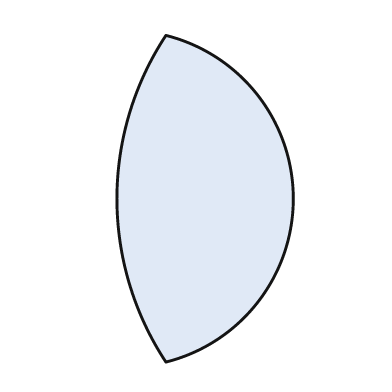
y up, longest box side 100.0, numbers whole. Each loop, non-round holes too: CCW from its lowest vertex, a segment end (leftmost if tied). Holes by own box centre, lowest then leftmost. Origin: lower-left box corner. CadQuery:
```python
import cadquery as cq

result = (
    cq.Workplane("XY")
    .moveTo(15.0, 0.0)
    .threePointArc((54.0, 50.0), (15.0, 100.0))
    .threePointArc((0.0, 50.0), (15.0, 0.0))
    .close()
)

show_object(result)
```